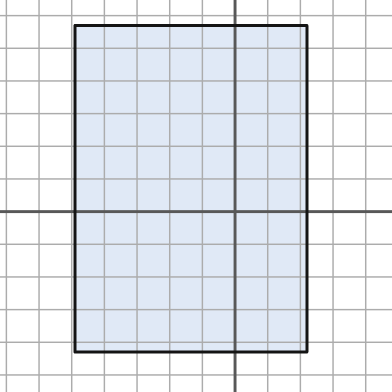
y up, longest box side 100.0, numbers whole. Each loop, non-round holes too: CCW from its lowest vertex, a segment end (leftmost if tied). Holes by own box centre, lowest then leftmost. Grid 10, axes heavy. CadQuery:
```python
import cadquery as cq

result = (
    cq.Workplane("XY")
    .moveTo(-49.0, -43.0)
    .lineTo(22.0, -43.0)
    .lineTo(22.0, 57.0)
    .lineTo(-49.0, 57.0)
    .close()
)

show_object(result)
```